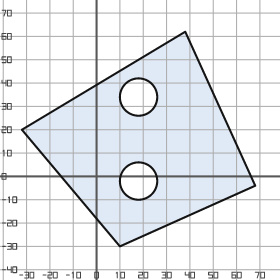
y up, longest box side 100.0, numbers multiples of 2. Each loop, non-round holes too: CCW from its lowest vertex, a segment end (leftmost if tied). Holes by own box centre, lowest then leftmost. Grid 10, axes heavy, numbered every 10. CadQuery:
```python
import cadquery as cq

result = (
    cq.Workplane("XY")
    .moveTo(10.0, -30.0)
    .lineTo(68.0, -4.0)
    .lineTo(38.0, 62.0)
    .lineTo(-32.0, 20.0)
    .close()
    .moveTo(18.0, -2.0)
    .circle(8.0)
    .moveTo(18.0, 34.0)
    .circle(8.0)
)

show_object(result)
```